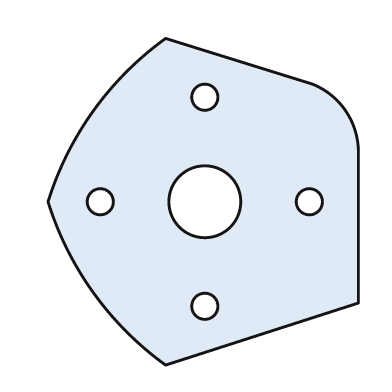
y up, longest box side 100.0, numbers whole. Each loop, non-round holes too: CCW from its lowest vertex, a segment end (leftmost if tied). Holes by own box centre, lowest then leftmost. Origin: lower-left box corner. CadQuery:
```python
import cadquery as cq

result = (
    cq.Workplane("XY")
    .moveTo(36.0, 0.0)
    .lineTo(95.0, 19.0)
    .lineTo(95.0, 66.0)
    .threePointArc((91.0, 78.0), (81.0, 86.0))
    .lineTo(36.0, 100.0)
    .threePointArc((14.0, 78.0), (0.0, 50.0))
    .threePointArc((14.0, 22.0), (36.0, 0.0))
    .close()
    .moveTo(48.0, 18.0)
    .circle(4.0)
    .moveTo(16.0, 50.0)
    .circle(4.0)
    .moveTo(48.0, 50.0)
    .circle(11.0)
    .moveTo(80.0, 50.0)
    .circle(4.0)
    .moveTo(48.0, 82.0)
    .circle(4.0)
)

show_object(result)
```